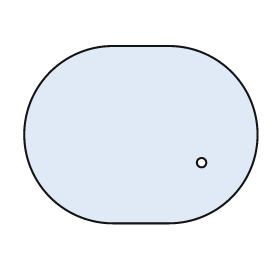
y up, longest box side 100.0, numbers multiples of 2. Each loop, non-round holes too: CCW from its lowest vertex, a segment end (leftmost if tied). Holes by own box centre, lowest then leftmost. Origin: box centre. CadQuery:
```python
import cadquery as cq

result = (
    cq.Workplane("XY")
    .moveTo(-12.0, -38.0)
    .lineTo(12.0, -38.0)
    .threePointArc((50.0, 0.0), (12.0, 38.0))
    .lineTo(-12.0, 38.0)
    .threePointArc((-50.0, 0.0), (-12.0, -38.0))
    .close()
    .moveTo(26.0, -12.0)
    .circle(2.0)
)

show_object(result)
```